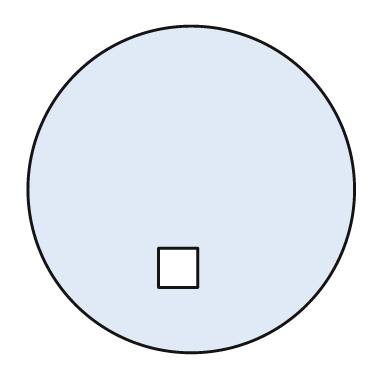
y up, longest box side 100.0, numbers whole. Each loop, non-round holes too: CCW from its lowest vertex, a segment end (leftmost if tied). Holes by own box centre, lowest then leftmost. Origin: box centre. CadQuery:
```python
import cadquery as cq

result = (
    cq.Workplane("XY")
    .moveTo(0.0, 0.0)
    .circle(50.0)
    .moveTo(-10.0, -30.0)
    .lineTo(2.0, -30.0)
    .lineTo(2.0, -18.0)
    .lineTo(-10.0, -18.0)
    .close()
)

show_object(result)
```